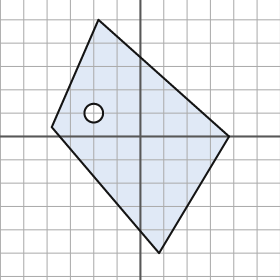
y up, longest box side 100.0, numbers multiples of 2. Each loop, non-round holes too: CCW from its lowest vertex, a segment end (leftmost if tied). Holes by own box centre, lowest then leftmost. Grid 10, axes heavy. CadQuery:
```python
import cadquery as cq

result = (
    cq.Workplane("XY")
    .moveTo(8.0, -50.0)
    .lineTo(38.0, 0.0)
    .lineTo(-18.0, 50.0)
    .lineTo(-38.0, 4.0)
    .close()
    .moveTo(-20.0, 10.0)
    .circle(4.0)
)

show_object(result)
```